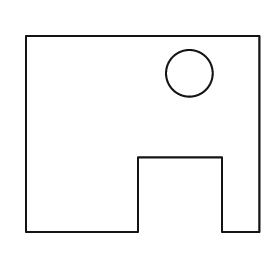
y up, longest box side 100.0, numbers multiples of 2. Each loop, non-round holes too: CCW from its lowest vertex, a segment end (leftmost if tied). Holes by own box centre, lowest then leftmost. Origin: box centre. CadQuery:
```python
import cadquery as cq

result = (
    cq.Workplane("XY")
    .moveTo(-50.0, -42.0)
    .lineTo(-2.0, -42.0)
    .lineTo(-2.0, -10.0)
    .lineTo(34.0, -10.0)
    .lineTo(34.0, -42.0)
    .lineTo(50.0, -42.0)
    .lineTo(50.0, 42.0)
    .lineTo(-50.0, 42.0)
    .close()
    .moveTo(20.0, 26.0)
    .circle(10.0)
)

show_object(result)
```